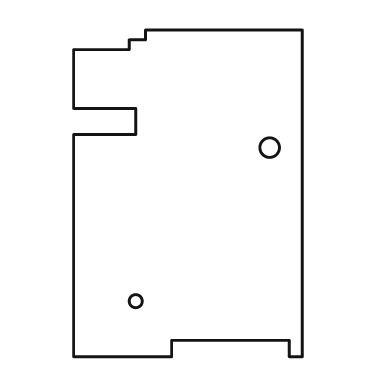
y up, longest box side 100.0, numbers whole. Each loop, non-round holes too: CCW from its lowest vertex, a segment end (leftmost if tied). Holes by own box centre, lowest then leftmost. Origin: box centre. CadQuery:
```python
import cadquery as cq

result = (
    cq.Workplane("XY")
    .moveTo(-35.0, -50.0)
    .lineTo(-5.0, -50.0)
    .lineTo(-5.0, -45.0)
    .lineTo(31.0, -45.0)
    .lineTo(31.0, -50.0)
    .lineTo(35.0, -50.0)
    .lineTo(35.0, 50.0)
    .lineTo(-13.0, 50.0)
    .lineTo(-13.0, 47.0)
    .lineTo(-18.0, 47.0)
    .lineTo(-18.0, 44.0)
    .lineTo(-35.0, 44.0)
    .lineTo(-35.0, 26.0)
    .lineTo(-16.0, 26.0)
    .lineTo(-16.0, 18.0)
    .lineTo(-35.0, 18.0)
    .close()
    .moveTo(-16.0, -33.0)
    .circle(2.0)
    .moveTo(25.0, 14.0)
    .circle(3.0)
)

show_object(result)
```